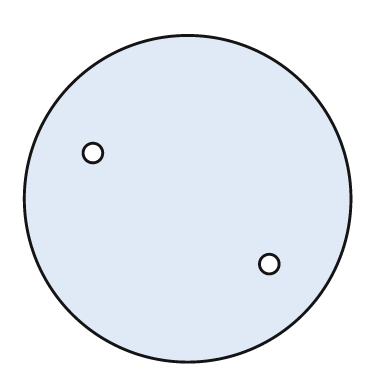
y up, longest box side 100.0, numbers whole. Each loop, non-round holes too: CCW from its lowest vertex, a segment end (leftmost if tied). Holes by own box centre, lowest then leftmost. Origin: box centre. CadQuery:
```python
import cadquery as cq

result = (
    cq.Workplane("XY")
    .moveTo(0.0, 0.0)
    .circle(50.0)
    .moveTo(25.0, -20.0)
    .circle(3.0)
    .moveTo(-29.0, 14.0)
    .circle(3.0)
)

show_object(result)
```